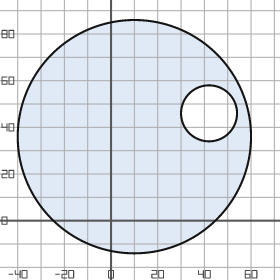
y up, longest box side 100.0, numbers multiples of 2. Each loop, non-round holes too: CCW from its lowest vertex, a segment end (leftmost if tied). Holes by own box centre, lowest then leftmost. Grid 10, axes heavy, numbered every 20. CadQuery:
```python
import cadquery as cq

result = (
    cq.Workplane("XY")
    .moveTo(10.0, 36.0)
    .circle(50.0)
    .moveTo(42.0, 46.0)
    .circle(12.0)
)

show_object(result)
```